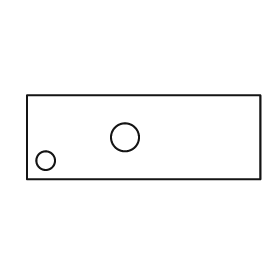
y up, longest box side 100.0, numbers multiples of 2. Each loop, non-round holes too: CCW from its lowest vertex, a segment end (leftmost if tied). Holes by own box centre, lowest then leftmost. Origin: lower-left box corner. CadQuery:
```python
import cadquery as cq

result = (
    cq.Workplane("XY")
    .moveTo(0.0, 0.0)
    .lineTo(100.0, 0.0)
    .lineTo(100.0, 36.0)
    .lineTo(0.0, 36.0)
    .close()
    .moveTo(8.0, 8.0)
    .circle(4.0)
    .moveTo(42.0, 18.0)
    .circle(6.0)
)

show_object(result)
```